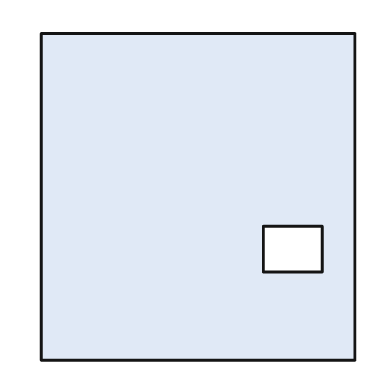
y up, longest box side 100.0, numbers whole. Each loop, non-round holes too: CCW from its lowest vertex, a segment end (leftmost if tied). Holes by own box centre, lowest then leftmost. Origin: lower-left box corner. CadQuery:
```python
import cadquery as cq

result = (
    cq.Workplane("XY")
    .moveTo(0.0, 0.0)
    .lineTo(96.0, 0.0)
    .lineTo(96.0, 100.0)
    .lineTo(0.0, 100.0)
    .close()
    .moveTo(68.0, 27.0)
    .lineTo(86.0, 27.0)
    .lineTo(86.0, 41.0)
    .lineTo(68.0, 41.0)
    .close()
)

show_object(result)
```